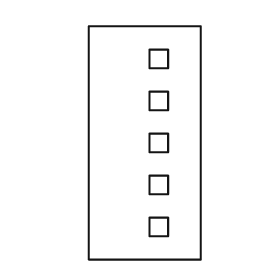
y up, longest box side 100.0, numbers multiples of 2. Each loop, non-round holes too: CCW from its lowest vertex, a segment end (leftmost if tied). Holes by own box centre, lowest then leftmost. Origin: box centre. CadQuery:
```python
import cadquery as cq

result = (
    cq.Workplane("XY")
    .moveTo(-24.0, -50.0)
    .lineTo(24.0, -50.0)
    .lineTo(24.0, 50.0)
    .lineTo(-24.0, 50.0)
    .close()
    .moveTo(2.0, -40.0)
    .lineTo(10.0, -40.0)
    .lineTo(10.0, -32.0)
    .lineTo(2.0, -32.0)
    .close()
    .moveTo(2.0, -22.0)
    .lineTo(10.0, -22.0)
    .lineTo(10.0, -14.0)
    .lineTo(2.0, -14.0)
    .close()
    .moveTo(2.0, -4.0)
    .lineTo(10.0, -4.0)
    .lineTo(10.0, 4.0)
    .lineTo(2.0, 4.0)
    .close()
    .moveTo(2.0, 14.0)
    .lineTo(10.0, 14.0)
    .lineTo(10.0, 22.0)
    .lineTo(2.0, 22.0)
    .close()
    .moveTo(2.0, 32.0)
    .lineTo(10.0, 32.0)
    .lineTo(10.0, 40.0)
    .lineTo(2.0, 40.0)
    .close()
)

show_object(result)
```